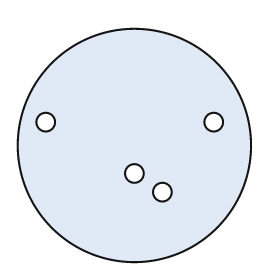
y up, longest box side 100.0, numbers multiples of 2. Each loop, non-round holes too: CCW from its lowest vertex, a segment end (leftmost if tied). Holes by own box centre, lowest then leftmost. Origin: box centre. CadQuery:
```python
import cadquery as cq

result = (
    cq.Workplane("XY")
    .moveTo(0.0, 0.0)
    .circle(50.0)
    .moveTo(12.0, -20.0)
    .circle(4.0)
    .moveTo(0.0, -12.0)
    .circle(4.0)
    .moveTo(-38.0, 10.0)
    .circle(4.0)
    .moveTo(34.0, 10.0)
    .circle(4.0)
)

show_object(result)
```